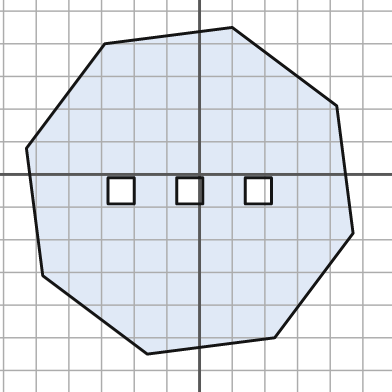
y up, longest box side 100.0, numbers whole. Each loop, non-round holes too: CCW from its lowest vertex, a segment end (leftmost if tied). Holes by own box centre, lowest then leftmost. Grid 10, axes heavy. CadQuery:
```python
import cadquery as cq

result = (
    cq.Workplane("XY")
    .moveTo(-16.0, -55.0)
    .lineTo(23.0, -50.0)
    .lineTo(47.0, -18.0)
    .lineTo(42.0, 21.0)
    .lineTo(10.0, 45.0)
    .lineTo(-29.0, 40.0)
    .lineTo(-53.0, 8.0)
    .lineTo(-48.0, -31.0)
    .close()
    .moveTo(-28.0, -9.0)
    .lineTo(-20.0, -9.0)
    .lineTo(-20.0, -1.0)
    .lineTo(-28.0, -1.0)
    .close()
    .moveTo(-7.0, -9.0)
    .lineTo(1.0, -9.0)
    .lineTo(1.0, -1.0)
    .lineTo(-7.0, -1.0)
    .close()
    .moveTo(14.0, -9.0)
    .lineTo(22.0, -9.0)
    .lineTo(22.0, -1.0)
    .lineTo(14.0, -1.0)
    .close()
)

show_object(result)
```